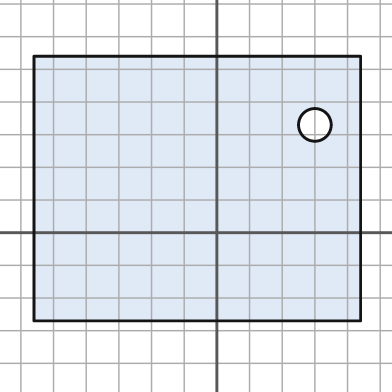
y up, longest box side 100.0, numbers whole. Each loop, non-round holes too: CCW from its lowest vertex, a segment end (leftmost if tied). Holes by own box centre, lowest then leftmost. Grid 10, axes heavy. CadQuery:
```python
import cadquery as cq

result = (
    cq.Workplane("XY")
    .moveTo(-56.0, -27.0)
    .lineTo(44.0, -27.0)
    .lineTo(44.0, 54.0)
    .lineTo(-56.0, 54.0)
    .close()
    .moveTo(30.0, 33.0)
    .circle(5.0)
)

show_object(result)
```